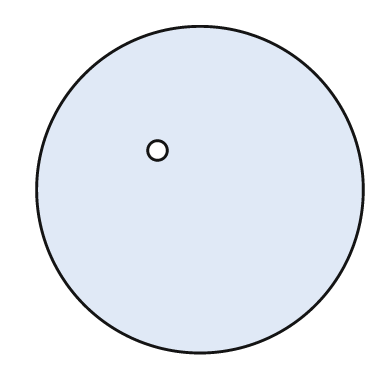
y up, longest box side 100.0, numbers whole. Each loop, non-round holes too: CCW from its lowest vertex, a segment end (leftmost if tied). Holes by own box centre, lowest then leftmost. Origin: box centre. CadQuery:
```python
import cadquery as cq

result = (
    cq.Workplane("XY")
    .moveTo(0.0, 0.0)
    .circle(50.0)
    .moveTo(-13.0, 12.0)
    .circle(3.0)
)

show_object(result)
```